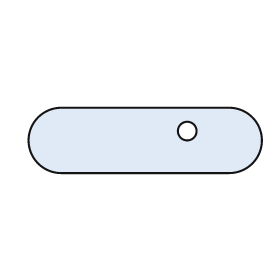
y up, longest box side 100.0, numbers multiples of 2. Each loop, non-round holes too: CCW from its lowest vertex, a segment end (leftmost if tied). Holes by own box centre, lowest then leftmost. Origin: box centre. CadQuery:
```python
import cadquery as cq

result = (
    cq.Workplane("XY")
    .moveTo(-36.0, -14.0)
    .lineTo(36.0, -14.0)
    .threePointArc((50.0, 0.0), (36.0, 14.0))
    .lineTo(-36.0, 14.0)
    .threePointArc((-50.0, 0.0), (-36.0, -14.0))
    .close()
    .moveTo(18.0, 4.0)
    .circle(4.0)
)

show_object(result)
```